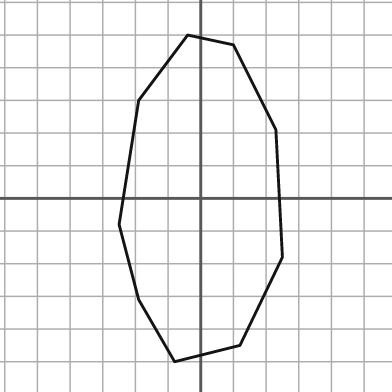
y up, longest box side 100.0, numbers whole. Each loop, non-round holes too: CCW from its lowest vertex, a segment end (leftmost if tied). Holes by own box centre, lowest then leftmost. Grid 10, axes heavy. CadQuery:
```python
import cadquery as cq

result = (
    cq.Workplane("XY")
    .moveTo(-8.0, -50.0)
    .lineTo(12.0, -45.0)
    .lineTo(25.0, -18.0)
    .lineTo(23.0, 21.0)
    .lineTo(10.0, 47.0)
    .lineTo(-4.0, 50.0)
    .lineTo(-19.0, 30.0)
    .lineTo(-25.0, -8.0)
    .lineTo(-19.0, -31.0)
    .close()
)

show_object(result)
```